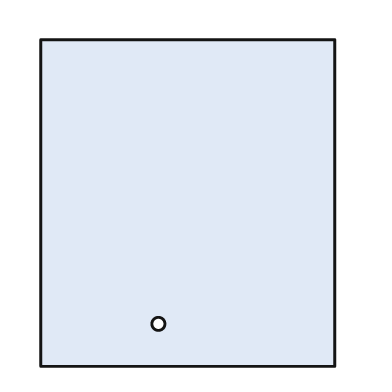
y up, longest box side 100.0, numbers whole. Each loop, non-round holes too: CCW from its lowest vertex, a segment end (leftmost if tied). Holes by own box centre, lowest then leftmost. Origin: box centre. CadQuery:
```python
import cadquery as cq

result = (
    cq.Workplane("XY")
    .moveTo(-45.0, -50.0)
    .lineTo(45.0, -50.0)
    .lineTo(45.0, 50.0)
    .lineTo(-45.0, 50.0)
    .close()
    .moveTo(-9.0, -37.0)
    .circle(2.0)
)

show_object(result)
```